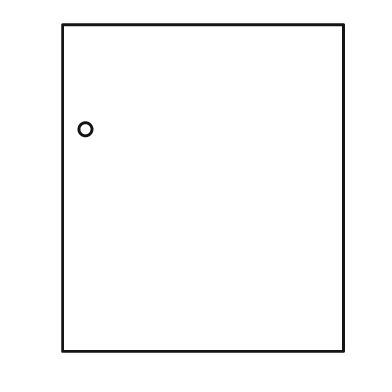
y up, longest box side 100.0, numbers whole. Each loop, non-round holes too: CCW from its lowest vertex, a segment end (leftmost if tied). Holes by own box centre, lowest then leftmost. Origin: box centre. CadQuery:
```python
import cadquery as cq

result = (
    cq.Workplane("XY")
    .moveTo(-43.0, -50.0)
    .lineTo(43.0, -50.0)
    .lineTo(43.0, 50.0)
    .lineTo(-43.0, 50.0)
    .close()
    .moveTo(-36.0, 18.0)
    .circle(2.0)
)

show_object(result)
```